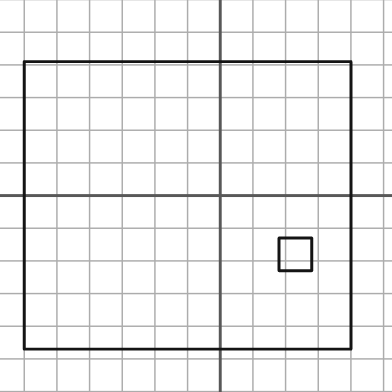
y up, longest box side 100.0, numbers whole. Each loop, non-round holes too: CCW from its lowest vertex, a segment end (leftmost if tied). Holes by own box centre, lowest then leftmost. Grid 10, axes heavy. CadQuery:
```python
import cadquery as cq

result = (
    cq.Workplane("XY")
    .moveTo(-60.0, -47.0)
    .lineTo(40.0, -47.0)
    .lineTo(40.0, 41.0)
    .lineTo(-60.0, 41.0)
    .close()
    .moveTo(18.0, -23.0)
    .lineTo(28.0, -23.0)
    .lineTo(28.0, -13.0)
    .lineTo(18.0, -13.0)
    .close()
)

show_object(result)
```